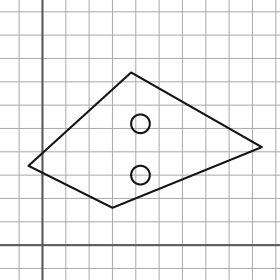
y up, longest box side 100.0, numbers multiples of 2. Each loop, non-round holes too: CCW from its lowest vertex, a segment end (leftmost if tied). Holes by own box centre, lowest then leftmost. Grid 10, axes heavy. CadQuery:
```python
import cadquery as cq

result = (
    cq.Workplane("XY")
    .moveTo(30.0, 16.0)
    .lineTo(94.0, 42.0)
    .lineTo(38.0, 74.0)
    .lineTo(-6.0, 34.0)
    .close()
    .moveTo(42.0, 30.0)
    .circle(4.0)
    .moveTo(42.0, 52.0)
    .circle(4.0)
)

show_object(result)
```